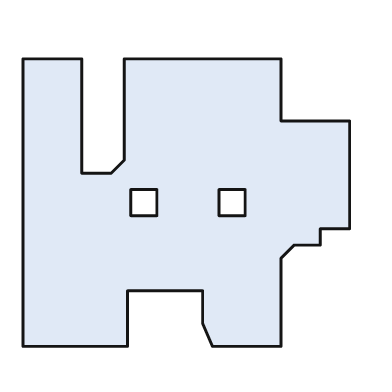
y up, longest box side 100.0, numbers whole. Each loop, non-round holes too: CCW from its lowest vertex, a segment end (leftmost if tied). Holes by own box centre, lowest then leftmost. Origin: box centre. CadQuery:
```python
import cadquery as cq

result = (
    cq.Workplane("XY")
    .moveTo(-50.0, -44.0)
    .lineTo(-18.0, -44.0)
    .lineTo(-18.0, -27.0)
    .lineTo(5.0, -27.0)
    .lineTo(5.0, -37.0)
    .lineTo(8.0, -44.0)
    .lineTo(29.0, -44.0)
    .lineTo(29.0, -17.0)
    .lineTo(33.0, -13.0)
    .lineTo(41.0, -13.0)
    .lineTo(41.0, -8.0)
    .lineTo(50.0, -8.0)
    .lineTo(50.0, 25.0)
    .lineTo(29.0, 25.0)
    .lineTo(29.0, 44.0)
    .lineTo(-19.0, 44.0)
    .lineTo(-19.0, 13.0)
    .lineTo(-23.0, 9.0)
    .lineTo(-32.0, 9.0)
    .lineTo(-32.0, 44.0)
    .lineTo(-50.0, 44.0)
    .close()
    .moveTo(-17.0, -4.0)
    .lineTo(-9.0, -4.0)
    .lineTo(-9.0, 4.0)
    .lineTo(-17.0, 4.0)
    .close()
    .moveTo(10.0, -4.0)
    .lineTo(18.0, -4.0)
    .lineTo(18.0, 4.0)
    .lineTo(10.0, 4.0)
    .close()
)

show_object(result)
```